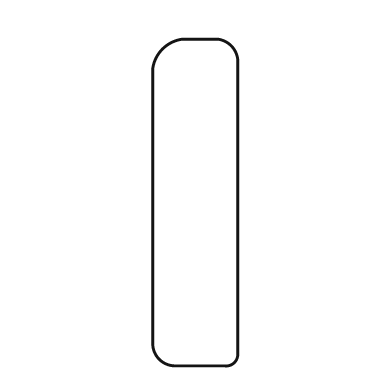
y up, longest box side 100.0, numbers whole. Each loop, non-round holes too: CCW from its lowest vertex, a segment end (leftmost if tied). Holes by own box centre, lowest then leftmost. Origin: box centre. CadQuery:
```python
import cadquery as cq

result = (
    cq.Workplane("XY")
    .moveTo(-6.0, -50.0)
    .lineTo(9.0, -50.0)
    .threePointArc((12.0, -49.0), (13.0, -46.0))
    .lineTo(13.0, 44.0)
    .threePointArc((11.0, 48.0), (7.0, 50.0))
    .lineTo(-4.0, 50.0)
    .threePointArc((-10.0, 47.0), (-13.0, 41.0))
    .lineTo(-13.0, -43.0)
    .threePointArc((-11.0, -48.0), (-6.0, -50.0))
    .close()
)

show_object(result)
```